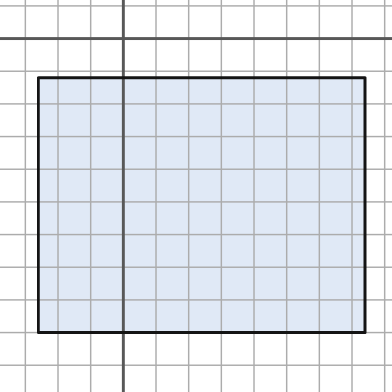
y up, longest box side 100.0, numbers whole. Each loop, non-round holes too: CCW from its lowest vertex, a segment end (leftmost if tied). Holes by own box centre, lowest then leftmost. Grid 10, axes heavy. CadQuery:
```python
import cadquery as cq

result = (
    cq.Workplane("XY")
    .moveTo(-26.0, -90.0)
    .lineTo(74.0, -90.0)
    .lineTo(74.0, -12.0)
    .lineTo(-26.0, -12.0)
    .close()
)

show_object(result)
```